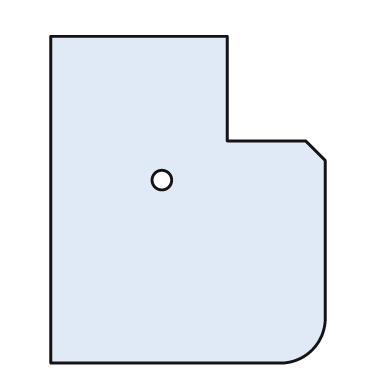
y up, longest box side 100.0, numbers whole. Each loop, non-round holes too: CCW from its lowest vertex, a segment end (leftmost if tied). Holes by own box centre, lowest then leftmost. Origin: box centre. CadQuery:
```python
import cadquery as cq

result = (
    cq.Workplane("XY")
    .moveTo(-42.0, -50.0)
    .lineTo(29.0, -50.0)
    .threePointArc((38.0, -46.0), (42.0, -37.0))
    .lineTo(42.0, 12.0)
    .lineTo(36.0, 18.0)
    .lineTo(12.0, 18.0)
    .lineTo(12.0, 50.0)
    .lineTo(-42.0, 50.0)
    .close()
    .moveTo(-8.0, 6.0)
    .circle(3.0)
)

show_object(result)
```